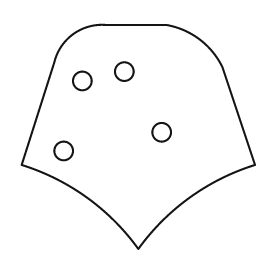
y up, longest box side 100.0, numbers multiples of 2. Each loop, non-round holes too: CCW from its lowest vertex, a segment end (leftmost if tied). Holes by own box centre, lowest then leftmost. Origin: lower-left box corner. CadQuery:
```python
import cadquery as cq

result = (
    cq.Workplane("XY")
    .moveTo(50.0, 0.0)
    .threePointArc((72.0, 22.0), (100.0, 36.0))
    .lineTo(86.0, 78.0)
    .threePointArc((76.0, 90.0), (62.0, 96.0))
    .lineTo(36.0, 96.0)
    .threePointArc((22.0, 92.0), (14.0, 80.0))
    .lineTo(0.0, 36.0)
    .threePointArc((28.0, 22.0), (50.0, 0.0))
    .close()
    .moveTo(18.0, 42.0)
    .circle(4.0)
    .moveTo(60.0, 50.0)
    .circle(4.0)
    .moveTo(26.0, 72.0)
    .circle(4.0)
    .moveTo(44.0, 76.0)
    .circle(4.0)
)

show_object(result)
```